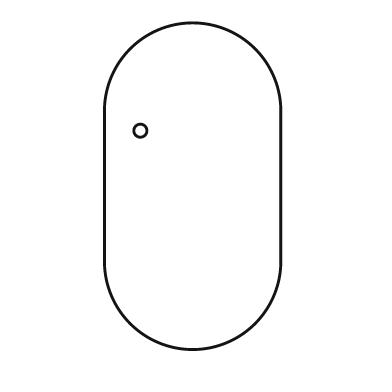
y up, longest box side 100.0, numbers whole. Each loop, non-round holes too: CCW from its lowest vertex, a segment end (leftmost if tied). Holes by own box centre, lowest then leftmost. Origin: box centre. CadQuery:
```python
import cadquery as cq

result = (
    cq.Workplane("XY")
    .moveTo(-27.0, -23.0)
    .threePointArc((0.0, -50.0), (27.0, -23.0))
    .lineTo(27.0, 23.0)
    .threePointArc((0.0, 50.0), (-27.0, 23.0))
    .close()
    .moveTo(-16.0, 17.0)
    .circle(2.0)
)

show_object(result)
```